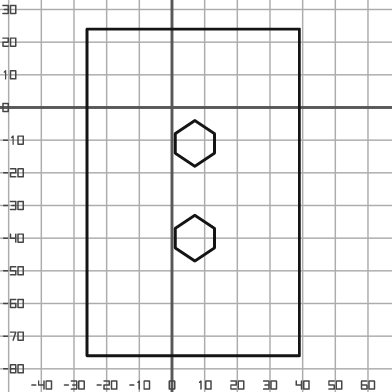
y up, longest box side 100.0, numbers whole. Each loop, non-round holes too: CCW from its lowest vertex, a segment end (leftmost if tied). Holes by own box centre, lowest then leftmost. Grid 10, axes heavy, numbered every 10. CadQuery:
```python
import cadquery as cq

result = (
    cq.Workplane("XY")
    .moveTo(-26.0, -76.0)
    .lineTo(39.0, -76.0)
    .lineTo(39.0, 24.0)
    .lineTo(-26.0, 24.0)
    .close()
    .moveTo(7.0, -47.0)
    .lineTo(13.0, -43.0)
    .lineTo(13.0, -37.0)
    .lineTo(7.0, -33.0)
    .lineTo(1.0, -37.0)
    .lineTo(1.0, -43.0)
    .close()
    .moveTo(7.0, -18.0)
    .lineTo(13.0, -14.0)
    .lineTo(13.0, -8.0)
    .lineTo(7.0, -4.0)
    .lineTo(1.0, -8.0)
    .lineTo(1.0, -14.0)
    .close()
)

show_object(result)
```